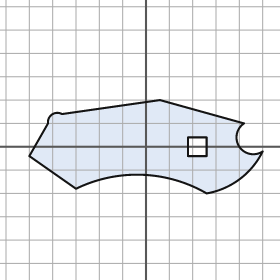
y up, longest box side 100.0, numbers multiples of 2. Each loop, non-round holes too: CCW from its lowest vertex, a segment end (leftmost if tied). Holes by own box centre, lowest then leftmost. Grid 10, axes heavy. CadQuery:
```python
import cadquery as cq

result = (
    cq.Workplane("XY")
    .moveTo(26.0, -20.0)
    .threePointArc((40.0, -14.0), (50.0, -2.0))
    .threePointArc((40.0, 0.0), (42.0, 10.0))
    .lineTo(6.0, 20.0)
    .lineTo(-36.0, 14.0)
    .threePointArc((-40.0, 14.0), (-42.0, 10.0))
    .lineTo(-50.0, -4.0)
    .lineTo(-30.0, -18.0)
    .threePointArc((-2.0, -12.0), (26.0, -20.0))
    .close()
    .moveTo(18.0, -4.0)
    .lineTo(26.0, -4.0)
    .lineTo(26.0, 4.0)
    .lineTo(18.0, 4.0)
    .close()
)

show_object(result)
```